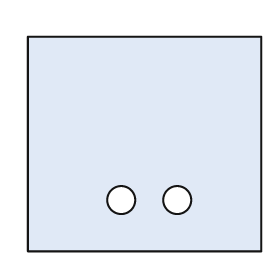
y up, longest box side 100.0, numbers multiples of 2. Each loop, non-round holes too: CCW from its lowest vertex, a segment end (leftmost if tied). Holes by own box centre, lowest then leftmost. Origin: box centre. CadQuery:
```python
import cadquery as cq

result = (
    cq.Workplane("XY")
    .moveTo(-50.0, -46.0)
    .lineTo(50.0, -46.0)
    .lineTo(50.0, 46.0)
    .lineTo(-50.0, 46.0)
    .close()
    .moveTo(-10.0, -24.0)
    .circle(6.0)
    .moveTo(14.0, -24.0)
    .circle(6.0)
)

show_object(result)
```